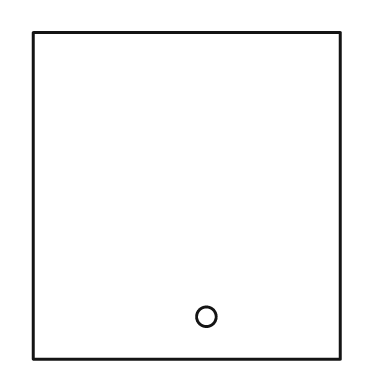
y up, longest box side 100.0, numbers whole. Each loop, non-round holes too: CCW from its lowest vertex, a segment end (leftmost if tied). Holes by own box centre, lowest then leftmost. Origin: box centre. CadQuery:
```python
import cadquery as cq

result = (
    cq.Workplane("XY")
    .moveTo(-47.0, -50.0)
    .lineTo(47.0, -50.0)
    .lineTo(47.0, 50.0)
    .lineTo(-47.0, 50.0)
    .close()
    .moveTo(6.0, -37.0)
    .circle(3.0)
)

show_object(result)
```